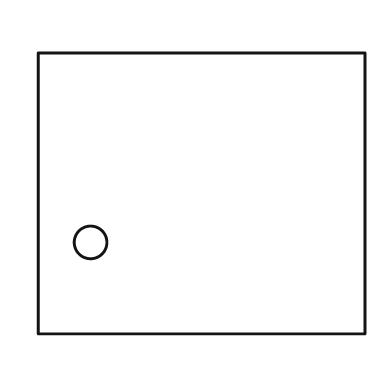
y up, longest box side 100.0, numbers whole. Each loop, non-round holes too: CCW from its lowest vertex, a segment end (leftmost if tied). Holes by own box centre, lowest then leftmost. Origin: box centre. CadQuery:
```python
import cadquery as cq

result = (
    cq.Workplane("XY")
    .moveTo(-50.0, -43.0)
    .lineTo(50.0, -43.0)
    .lineTo(50.0, 43.0)
    .lineTo(-50.0, 43.0)
    .close()
    .moveTo(-34.0, -15.0)
    .circle(5.0)
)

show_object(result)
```